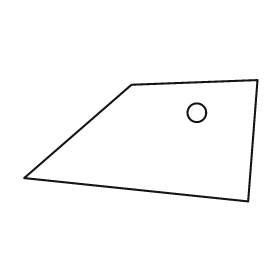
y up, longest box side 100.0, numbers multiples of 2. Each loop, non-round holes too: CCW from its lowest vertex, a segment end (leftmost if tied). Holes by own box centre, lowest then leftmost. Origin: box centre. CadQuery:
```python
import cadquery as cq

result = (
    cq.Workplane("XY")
    .moveTo(46.0, -26.0)
    .lineTo(50.0, 26.0)
    .lineTo(-4.0, 24.0)
    .lineTo(-50.0, -16.0)
    .close()
    .moveTo(24.0, 12.0)
    .circle(4.0)
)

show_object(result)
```